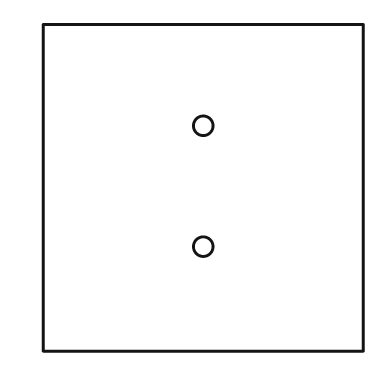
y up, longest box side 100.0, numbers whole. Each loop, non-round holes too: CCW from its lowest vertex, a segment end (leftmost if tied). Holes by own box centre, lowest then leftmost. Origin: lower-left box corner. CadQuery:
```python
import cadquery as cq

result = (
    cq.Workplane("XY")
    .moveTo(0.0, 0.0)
    .lineTo(98.0, 0.0)
    .lineTo(98.0, 100.0)
    .lineTo(0.0, 100.0)
    .close()
    .moveTo(49.0, 32.0)
    .circle(3.0)
    .moveTo(49.0, 69.0)
    .circle(3.0)
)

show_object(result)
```